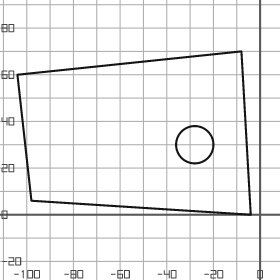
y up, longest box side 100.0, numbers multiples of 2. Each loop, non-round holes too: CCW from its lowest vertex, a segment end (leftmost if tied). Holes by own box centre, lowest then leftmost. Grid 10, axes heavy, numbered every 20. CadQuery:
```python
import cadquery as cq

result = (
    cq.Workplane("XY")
    .moveTo(-4.0, 0.0)
    .lineTo(-8.0, 70.0)
    .lineTo(-104.0, 60.0)
    .lineTo(-98.0, 6.0)
    .close()
    .moveTo(-28.0, 30.0)
    .circle(8.0)
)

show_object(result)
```